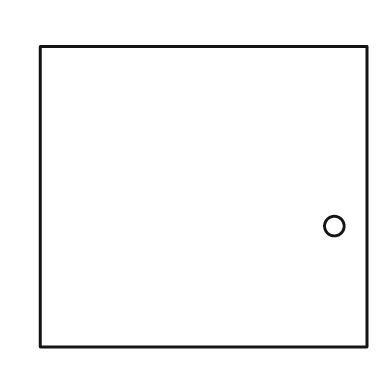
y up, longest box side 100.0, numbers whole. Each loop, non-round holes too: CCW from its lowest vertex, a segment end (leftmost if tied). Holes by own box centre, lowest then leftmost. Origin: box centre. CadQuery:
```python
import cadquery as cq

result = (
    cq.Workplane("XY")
    .moveTo(-50.0, -46.0)
    .lineTo(50.0, -46.0)
    .lineTo(50.0, 46.0)
    .lineTo(-50.0, 46.0)
    .close()
    .moveTo(40.0, -9.0)
    .circle(3.0)
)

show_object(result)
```